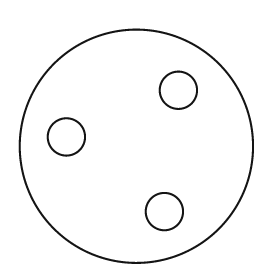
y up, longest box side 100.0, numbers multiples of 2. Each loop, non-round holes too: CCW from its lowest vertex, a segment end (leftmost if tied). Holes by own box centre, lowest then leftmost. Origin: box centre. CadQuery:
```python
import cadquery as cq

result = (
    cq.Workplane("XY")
    .moveTo(0.0, 0.0)
    .circle(50.0)
    .moveTo(12.0, -28.0)
    .circle(8.0)
    .moveTo(-30.0, 4.0)
    .circle(8.0)
    .moveTo(18.0, 24.0)
    .circle(8.0)
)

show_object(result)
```